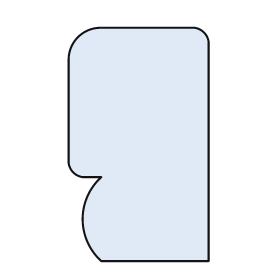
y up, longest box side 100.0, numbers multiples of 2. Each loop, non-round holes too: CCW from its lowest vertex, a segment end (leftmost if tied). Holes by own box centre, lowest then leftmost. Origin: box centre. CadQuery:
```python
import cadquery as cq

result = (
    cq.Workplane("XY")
    .moveTo(-16.0, -50.0)
    .lineTo(30.0, -50.0)
    .lineTo(30.0, 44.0)
    .threePointArc((28.0, 48.0), (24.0, 50.0))
    .lineTo(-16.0, 50.0)
    .threePointArc((-26.0, 46.0), (-30.0, 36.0))
    .lineTo(-30.0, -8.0)
    .threePointArc((-28.0, -12.0), (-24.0, -14.0))
    .lineTo(-16.0, -14.0)
    .threePointArc((-24.0, -32.0), (-16.0, -50.0))
    .close()
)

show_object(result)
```